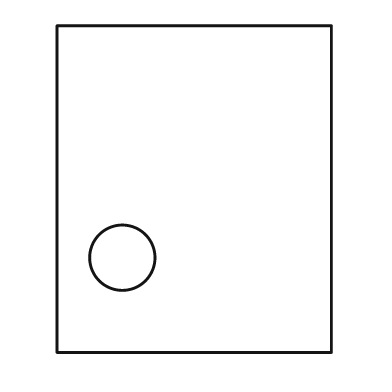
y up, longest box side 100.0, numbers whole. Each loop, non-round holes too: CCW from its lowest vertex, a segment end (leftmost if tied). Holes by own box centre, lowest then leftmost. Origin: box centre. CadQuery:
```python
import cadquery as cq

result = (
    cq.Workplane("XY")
    .moveTo(-42.0, -50.0)
    .lineTo(42.0, -50.0)
    .lineTo(42.0, 50.0)
    .lineTo(-42.0, 50.0)
    .close()
    .moveTo(-22.0, -21.0)
    .circle(10.0)
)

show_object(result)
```